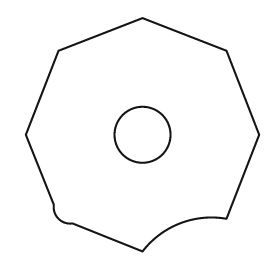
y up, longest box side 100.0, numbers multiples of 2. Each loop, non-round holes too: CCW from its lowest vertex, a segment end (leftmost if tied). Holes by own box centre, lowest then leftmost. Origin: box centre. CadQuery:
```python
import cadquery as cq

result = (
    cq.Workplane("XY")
    .moveTo(0.0, -50.0)
    .threePointArc((16.0, -38.0), (36.0, -36.0))
    .lineTo(50.0, 0.0)
    .lineTo(36.0, 36.0)
    .lineTo(0.0, 50.0)
    .lineTo(-36.0, 36.0)
    .lineTo(-50.0, 0.0)
    .lineTo(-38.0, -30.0)
    .threePointArc((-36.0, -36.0), (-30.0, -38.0))
    .close()
    .moveTo(0.0, 0.0)
    .circle(12.0)
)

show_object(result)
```